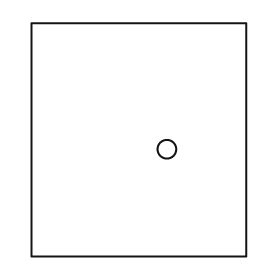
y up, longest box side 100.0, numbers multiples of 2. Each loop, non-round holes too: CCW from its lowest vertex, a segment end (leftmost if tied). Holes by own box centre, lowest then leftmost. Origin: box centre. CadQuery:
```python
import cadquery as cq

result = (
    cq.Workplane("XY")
    .moveTo(-46.0, -50.0)
    .lineTo(46.0, -50.0)
    .lineTo(46.0, 50.0)
    .lineTo(-46.0, 50.0)
    .close()
    .moveTo(12.0, -4.0)
    .circle(4.0)
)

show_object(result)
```